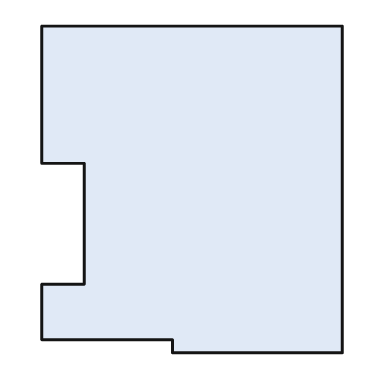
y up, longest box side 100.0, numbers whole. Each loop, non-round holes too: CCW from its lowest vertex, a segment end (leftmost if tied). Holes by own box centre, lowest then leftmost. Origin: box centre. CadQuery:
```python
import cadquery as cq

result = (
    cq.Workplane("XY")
    .moveTo(-6.0, -50.0)
    .lineTo(46.0, -50.0)
    .lineTo(46.0, 50.0)
    .lineTo(-46.0, 50.0)
    .lineTo(-46.0, 8.0)
    .lineTo(-33.0, 8.0)
    .lineTo(-33.0, -29.0)
    .lineTo(-46.0, -29.0)
    .lineTo(-46.0, -46.0)
    .lineTo(-6.0, -46.0)
    .close()
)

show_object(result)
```